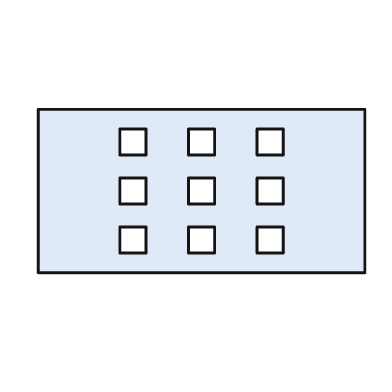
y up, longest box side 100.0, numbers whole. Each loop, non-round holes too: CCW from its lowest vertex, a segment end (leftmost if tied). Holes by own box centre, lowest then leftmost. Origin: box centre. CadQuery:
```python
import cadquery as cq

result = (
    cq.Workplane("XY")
    .moveTo(-50.0, -25.0)
    .lineTo(50.0, -25.0)
    .lineTo(50.0, 25.0)
    .lineTo(-50.0, 25.0)
    .close()
    .moveTo(-25.0, -19.0)
    .lineTo(-17.0, -19.0)
    .lineTo(-17.0, -11.0)
    .lineTo(-25.0, -11.0)
    .close()
    .moveTo(-4.0, -19.0)
    .lineTo(4.0, -19.0)
    .lineTo(4.0, -11.0)
    .lineTo(-4.0, -11.0)
    .close()
    .moveTo(17.0, -19.0)
    .lineTo(25.0, -19.0)
    .lineTo(25.0, -11.0)
    .lineTo(17.0, -11.0)
    .close()
    .moveTo(-25.0, -4.0)
    .lineTo(-17.0, -4.0)
    .lineTo(-17.0, 4.0)
    .lineTo(-25.0, 4.0)
    .close()
    .moveTo(-4.0, -4.0)
    .lineTo(4.0, -4.0)
    .lineTo(4.0, 4.0)
    .lineTo(-4.0, 4.0)
    .close()
    .moveTo(17.0, -4.0)
    .lineTo(25.0, -4.0)
    .lineTo(25.0, 4.0)
    .lineTo(17.0, 4.0)
    .close()
    .moveTo(-25.0, 11.0)
    .lineTo(-17.0, 11.0)
    .lineTo(-17.0, 19.0)
    .lineTo(-25.0, 19.0)
    .close()
    .moveTo(-4.0, 11.0)
    .lineTo(4.0, 11.0)
    .lineTo(4.0, 19.0)
    .lineTo(-4.0, 19.0)
    .close()
    .moveTo(17.0, 11.0)
    .lineTo(25.0, 11.0)
    .lineTo(25.0, 19.0)
    .lineTo(17.0, 19.0)
    .close()
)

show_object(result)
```